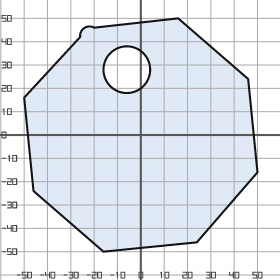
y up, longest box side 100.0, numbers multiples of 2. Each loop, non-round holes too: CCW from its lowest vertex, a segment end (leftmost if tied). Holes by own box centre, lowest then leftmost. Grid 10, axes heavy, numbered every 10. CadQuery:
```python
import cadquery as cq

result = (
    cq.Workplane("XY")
    .moveTo(-16.0, -50.0)
    .lineTo(24.0, -46.0)
    .lineTo(50.0, -16.0)
    .lineTo(46.0, 24.0)
    .lineTo(16.0, 50.0)
    .lineTo(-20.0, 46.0)
    .threePointArc((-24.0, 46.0), (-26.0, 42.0))
    .lineTo(-50.0, 16.0)
    .lineTo(-46.0, -24.0)
    .close()
    .moveTo(-6.0, 28.0)
    .circle(10.0)
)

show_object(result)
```